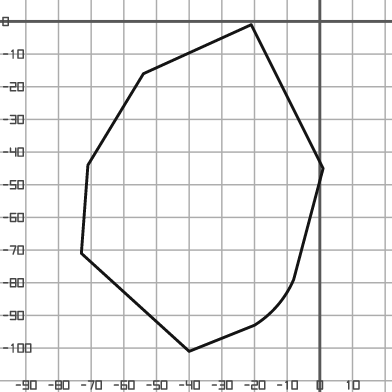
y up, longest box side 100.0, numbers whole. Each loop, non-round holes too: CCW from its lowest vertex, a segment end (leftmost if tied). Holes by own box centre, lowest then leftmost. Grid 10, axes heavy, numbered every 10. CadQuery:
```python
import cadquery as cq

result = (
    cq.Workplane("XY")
    .moveTo(-40.0, -101.0)
    .lineTo(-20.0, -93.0)
    .threePointArc((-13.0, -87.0), (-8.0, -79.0))
    .lineTo(1.0, -45.0)
    .lineTo(-21.0, -1.0)
    .lineTo(-54.0, -16.0)
    .lineTo(-71.0, -44.0)
    .lineTo(-73.0, -71.0)
    .close()
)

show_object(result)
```